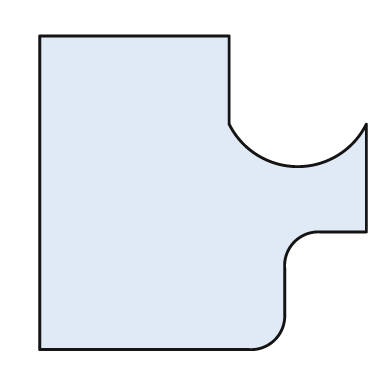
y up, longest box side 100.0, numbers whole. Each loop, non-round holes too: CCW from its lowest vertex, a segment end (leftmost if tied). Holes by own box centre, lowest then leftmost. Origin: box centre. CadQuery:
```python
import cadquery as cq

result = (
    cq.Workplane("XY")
    .moveTo(-50.0, -48.0)
    .lineTo(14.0, -48.0)
    .threePointArc((22.0, -45.0), (25.0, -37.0))
    .lineTo(25.0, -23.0)
    .threePointArc((28.0, -15.0), (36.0, -12.0))
    .lineTo(50.0, -12.0)
    .lineTo(50.0, 21.0)
    .threePointArc((29.0, 8.0), (8.0, 21.0))
    .lineTo(8.0, 48.0)
    .lineTo(-50.0, 48.0)
    .close()
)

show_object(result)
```